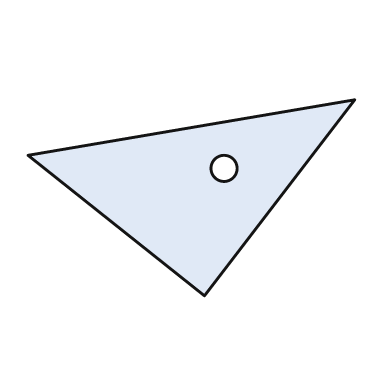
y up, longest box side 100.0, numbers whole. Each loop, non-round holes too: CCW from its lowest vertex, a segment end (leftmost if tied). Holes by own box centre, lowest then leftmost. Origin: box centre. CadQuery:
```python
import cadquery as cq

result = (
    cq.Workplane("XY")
    .moveTo(4.0, -30.0)
    .lineTo(50.0, 30.0)
    .lineTo(-50.0, 13.0)
    .close()
    .moveTo(10.0, 9.0)
    .circle(4.0)
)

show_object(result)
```